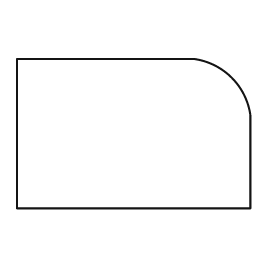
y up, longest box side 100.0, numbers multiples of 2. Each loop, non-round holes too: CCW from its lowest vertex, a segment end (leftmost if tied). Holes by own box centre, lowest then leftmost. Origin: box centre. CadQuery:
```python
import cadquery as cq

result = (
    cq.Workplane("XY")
    .moveTo(-50.0, -32.0)
    .lineTo(50.0, -32.0)
    .lineTo(50.0, 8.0)
    .threePointArc((42.0, 24.0), (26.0, 32.0))
    .lineTo(-50.0, 32.0)
    .close()
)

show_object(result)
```